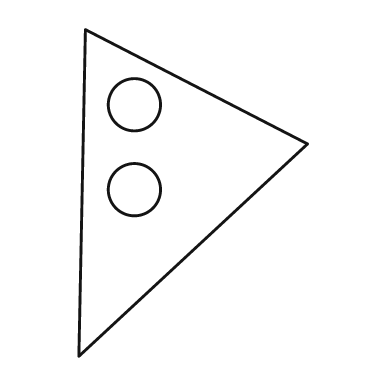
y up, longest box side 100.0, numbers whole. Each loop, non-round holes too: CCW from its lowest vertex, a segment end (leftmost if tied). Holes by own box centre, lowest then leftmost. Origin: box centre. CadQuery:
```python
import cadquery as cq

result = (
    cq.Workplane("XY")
    .moveTo(-35.0, -50.0)
    .lineTo(35.0, 15.0)
    .lineTo(-33.0, 50.0)
    .close()
    .moveTo(-18.0, 1.0)
    .circle(8.0)
    .moveTo(-18.0, 27.0)
    .circle(8.0)
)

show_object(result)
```